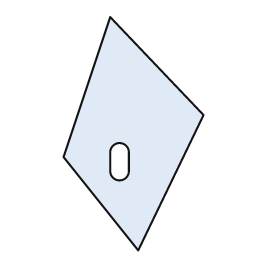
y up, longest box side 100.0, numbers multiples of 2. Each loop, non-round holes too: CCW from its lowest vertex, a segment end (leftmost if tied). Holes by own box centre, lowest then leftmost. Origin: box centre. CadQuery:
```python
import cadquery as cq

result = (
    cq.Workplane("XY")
    .moveTo(2.0, -50.0)
    .lineTo(30.0, 8.0)
    .lineTo(-10.0, 50.0)
    .lineTo(-30.0, -10.0)
    .close()
    .moveTo(-10.0, -16.0)
    .threePointArc((-6.0, -20.0), (-2.0, -16.0))
    .lineTo(-2.0, -8.0)
    .threePointArc((-6.0, -4.0), (-10.0, -8.0))
    .close()
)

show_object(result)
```